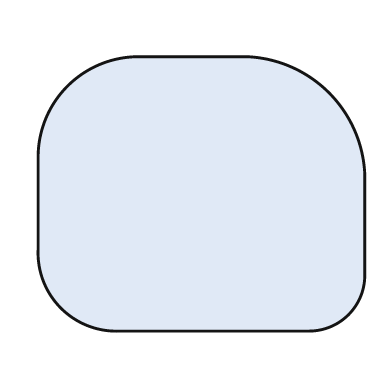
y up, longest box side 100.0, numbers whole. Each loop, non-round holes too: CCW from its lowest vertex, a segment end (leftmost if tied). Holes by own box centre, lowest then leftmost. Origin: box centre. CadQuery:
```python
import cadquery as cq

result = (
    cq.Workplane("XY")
    .moveTo(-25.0, -42.0)
    .lineTo(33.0, -42.0)
    .threePointArc((45.0, -37.0), (50.0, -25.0))
    .lineTo(50.0, 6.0)
    .threePointArc((39.0, 31.0), (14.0, 42.0))
    .lineTo(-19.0, 42.0)
    .threePointArc((-41.0, 33.0), (-50.0, 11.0))
    .lineTo(-50.0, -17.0)
    .threePointArc((-43.0, -35.0), (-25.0, -42.0))
    .close()
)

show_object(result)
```